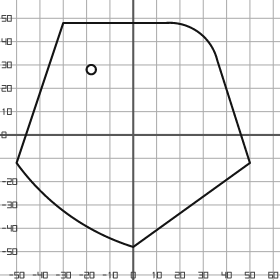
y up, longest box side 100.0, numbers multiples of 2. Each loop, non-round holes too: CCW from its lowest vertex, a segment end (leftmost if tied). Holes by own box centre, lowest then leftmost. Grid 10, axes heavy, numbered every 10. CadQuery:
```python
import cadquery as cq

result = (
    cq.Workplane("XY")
    .moveTo(0.0, -48.0)
    .lineTo(50.0, -12.0)
    .lineTo(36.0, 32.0)
    .threePointArc((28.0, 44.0), (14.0, 48.0))
    .lineTo(-30.0, 48.0)
    .lineTo(-50.0, -12.0)
    .threePointArc((-28.0, -34.0), (0.0, -48.0))
    .close()
    .moveTo(-18.0, 28.0)
    .circle(2.0)
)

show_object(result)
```